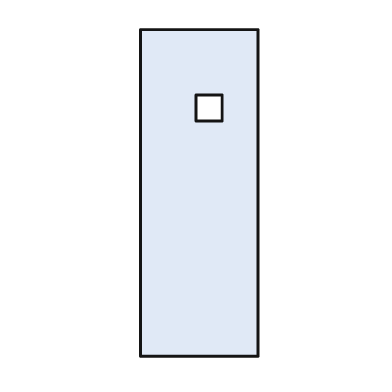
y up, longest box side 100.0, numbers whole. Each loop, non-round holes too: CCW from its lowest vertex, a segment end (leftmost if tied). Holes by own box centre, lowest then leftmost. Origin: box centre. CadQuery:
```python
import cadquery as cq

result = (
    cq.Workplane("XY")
    .moveTo(-18.0, -50.0)
    .lineTo(18.0, -50.0)
    .lineTo(18.0, 50.0)
    .lineTo(-18.0, 50.0)
    .close()
    .moveTo(-1.0, 22.0)
    .lineTo(7.0, 22.0)
    .lineTo(7.0, 30.0)
    .lineTo(-1.0, 30.0)
    .close()
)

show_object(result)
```